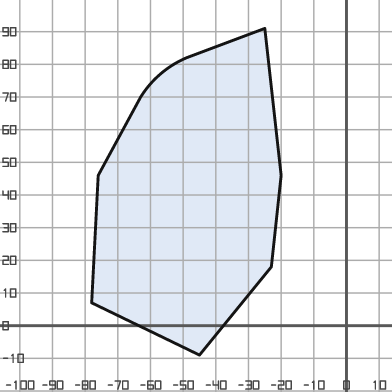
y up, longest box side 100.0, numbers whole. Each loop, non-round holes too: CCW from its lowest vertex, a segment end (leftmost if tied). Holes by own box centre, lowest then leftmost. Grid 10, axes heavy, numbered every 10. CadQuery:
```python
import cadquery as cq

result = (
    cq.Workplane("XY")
    .moveTo(-45.0, -9.0)
    .lineTo(-23.0, 18.0)
    .lineTo(-20.0, 46.0)
    .lineTo(-25.0, 91.0)
    .lineTo(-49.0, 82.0)
    .threePointArc((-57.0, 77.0), (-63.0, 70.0))
    .lineTo(-76.0, 46.0)
    .lineTo(-78.0, 7.0)
    .close()
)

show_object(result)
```